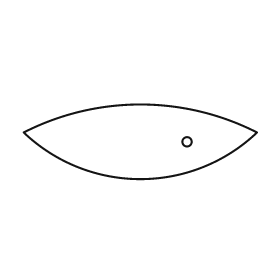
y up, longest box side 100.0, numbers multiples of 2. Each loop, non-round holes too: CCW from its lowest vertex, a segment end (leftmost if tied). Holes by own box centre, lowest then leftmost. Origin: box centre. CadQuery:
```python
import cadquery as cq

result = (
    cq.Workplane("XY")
    .moveTo(-50.0, 4.0)
    .threePointArc((0.0, -16.0), (50.0, 4.0))
    .threePointArc((0.0, 16.0), (-50.0, 4.0))
    .close()
    .moveTo(20.0, 0.0)
    .circle(2.0)
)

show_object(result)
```